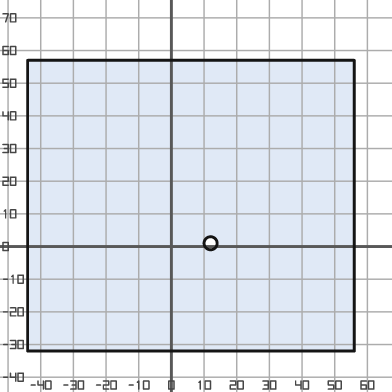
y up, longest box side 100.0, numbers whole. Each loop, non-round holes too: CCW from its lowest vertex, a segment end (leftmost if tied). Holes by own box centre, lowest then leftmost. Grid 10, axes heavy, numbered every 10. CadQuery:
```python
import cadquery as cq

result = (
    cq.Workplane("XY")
    .moveTo(-44.0, -32.0)
    .lineTo(56.0, -32.0)
    .lineTo(56.0, 57.0)
    .lineTo(-44.0, 57.0)
    .close()
    .moveTo(12.0, 1.0)
    .circle(2.0)
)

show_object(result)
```